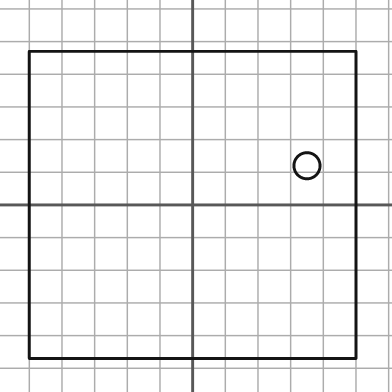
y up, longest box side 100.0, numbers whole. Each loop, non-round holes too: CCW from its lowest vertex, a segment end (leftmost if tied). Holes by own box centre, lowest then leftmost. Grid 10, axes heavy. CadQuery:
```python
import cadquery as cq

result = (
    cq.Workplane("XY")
    .moveTo(-50.0, -47.0)
    .lineTo(50.0, -47.0)
    .lineTo(50.0, 47.0)
    .lineTo(-50.0, 47.0)
    .close()
    .moveTo(35.0, 12.0)
    .circle(4.0)
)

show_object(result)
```